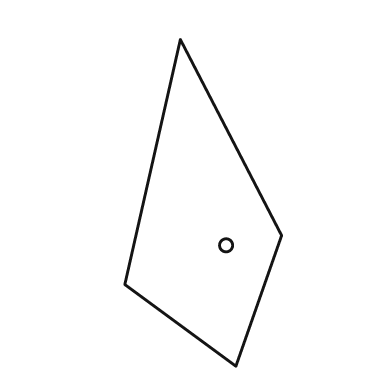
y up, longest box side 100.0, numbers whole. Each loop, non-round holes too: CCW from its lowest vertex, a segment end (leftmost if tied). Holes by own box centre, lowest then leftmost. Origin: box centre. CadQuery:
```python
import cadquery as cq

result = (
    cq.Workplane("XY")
    .moveTo(10.0, -50.0)
    .lineTo(24.0, -10.0)
    .lineTo(-7.0, 50.0)
    .lineTo(-24.0, -25.0)
    .close()
    .moveTo(7.0, -13.0)
    .circle(2.0)
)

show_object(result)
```